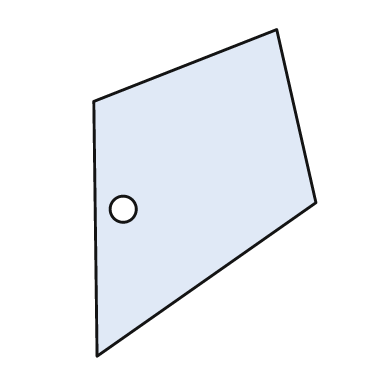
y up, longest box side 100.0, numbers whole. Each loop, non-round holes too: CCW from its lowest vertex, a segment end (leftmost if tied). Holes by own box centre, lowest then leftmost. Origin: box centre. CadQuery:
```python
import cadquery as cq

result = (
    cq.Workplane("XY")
    .moveTo(-33.0, -50.0)
    .lineTo(34.0, -3.0)
    .lineTo(22.0, 50.0)
    .lineTo(-34.0, 28.0)
    .close()
    .moveTo(-25.0, -5.0)
    .circle(4.0)
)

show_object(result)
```